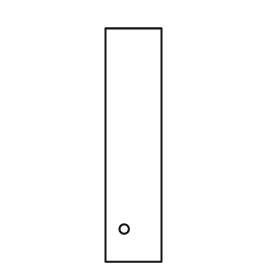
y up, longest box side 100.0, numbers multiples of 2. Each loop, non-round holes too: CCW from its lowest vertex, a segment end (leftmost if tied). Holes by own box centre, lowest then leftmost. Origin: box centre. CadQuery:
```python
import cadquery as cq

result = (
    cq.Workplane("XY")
    .moveTo(-12.0, -50.0)
    .lineTo(12.0, -50.0)
    .lineTo(12.0, 50.0)
    .lineTo(-12.0, 50.0)
    .close()
    .moveTo(-4.0, -36.0)
    .circle(2.0)
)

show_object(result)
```